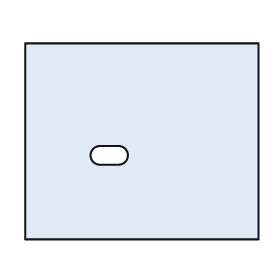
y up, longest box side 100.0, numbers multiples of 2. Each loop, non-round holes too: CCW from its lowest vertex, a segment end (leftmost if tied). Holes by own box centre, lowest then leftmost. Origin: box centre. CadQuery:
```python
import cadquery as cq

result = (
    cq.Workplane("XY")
    .moveTo(-50.0, -42.0)
    .lineTo(50.0, -42.0)
    .lineTo(50.0, 42.0)
    .lineTo(-50.0, 42.0)
    .close()
    .moveTo(-18.0, -10.0)
    .lineTo(-10.0, -10.0)
    .threePointArc((-6.0, -6.0), (-10.0, -2.0))
    .lineTo(-18.0, -2.0)
    .threePointArc((-22.0, -6.0), (-18.0, -10.0))
    .close()
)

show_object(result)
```